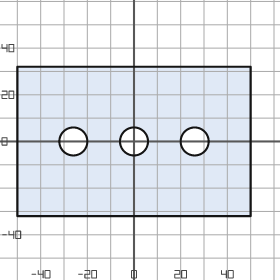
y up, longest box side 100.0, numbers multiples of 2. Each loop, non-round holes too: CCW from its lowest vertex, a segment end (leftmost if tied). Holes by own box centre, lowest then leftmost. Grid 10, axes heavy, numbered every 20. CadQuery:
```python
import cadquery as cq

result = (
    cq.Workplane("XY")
    .moveTo(-50.0, -32.0)
    .lineTo(50.0, -32.0)
    .lineTo(50.0, 32.0)
    .lineTo(-50.0, 32.0)
    .close()
    .moveTo(-26.0, 0.0)
    .circle(6.0)
    .moveTo(0.0, 0.0)
    .circle(6.0)
    .moveTo(26.0, 0.0)
    .circle(6.0)
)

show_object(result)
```